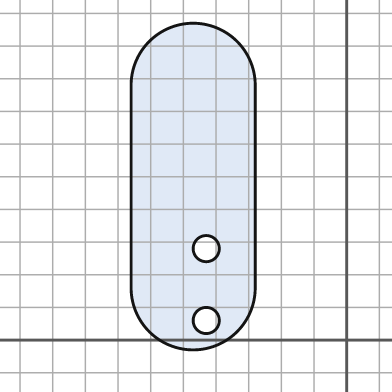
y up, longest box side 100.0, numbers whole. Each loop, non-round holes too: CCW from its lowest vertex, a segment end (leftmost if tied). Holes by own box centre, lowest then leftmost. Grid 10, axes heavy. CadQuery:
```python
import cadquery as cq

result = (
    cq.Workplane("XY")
    .moveTo(-66.0, 16.0)
    .threePointArc((-47.0, -3.0), (-28.0, 16.0))
    .lineTo(-28.0, 78.0)
    .threePointArc((-47.0, 97.0), (-66.0, 78.0))
    .close()
    .moveTo(-43.0, 6.0)
    .circle(4.0)
    .moveTo(-43.0, 28.0)
    .circle(4.0)
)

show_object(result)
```